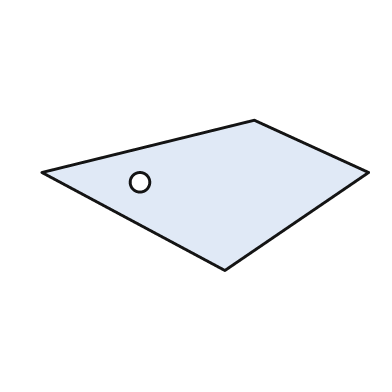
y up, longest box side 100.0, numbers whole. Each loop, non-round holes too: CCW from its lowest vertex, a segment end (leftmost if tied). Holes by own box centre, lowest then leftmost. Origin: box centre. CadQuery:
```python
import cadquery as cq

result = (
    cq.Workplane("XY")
    .moveTo(6.0, -23.0)
    .lineTo(50.0, 7.0)
    .lineTo(15.0, 23.0)
    .lineTo(-50.0, 7.0)
    .close()
    .moveTo(-20.0, 4.0)
    .circle(3.0)
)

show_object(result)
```